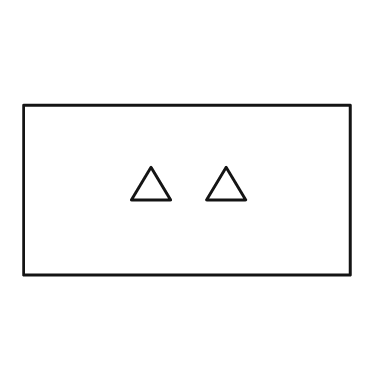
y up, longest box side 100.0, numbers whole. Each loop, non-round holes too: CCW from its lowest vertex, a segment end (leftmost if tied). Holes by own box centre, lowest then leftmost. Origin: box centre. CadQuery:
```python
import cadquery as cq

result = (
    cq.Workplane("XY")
    .moveTo(-50.0, -26.0)
    .lineTo(50.0, -26.0)
    .lineTo(50.0, 26.0)
    .lineTo(-50.0, 26.0)
    .close()
    .moveTo(-17.0, -3.0)
    .lineTo(-5.0, -3.0)
    .lineTo(-11.0, 7.0)
    .close()
    .moveTo(6.0, -3.0)
    .lineTo(18.0, -3.0)
    .lineTo(12.0, 7.0)
    .close()
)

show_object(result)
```